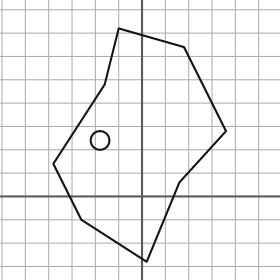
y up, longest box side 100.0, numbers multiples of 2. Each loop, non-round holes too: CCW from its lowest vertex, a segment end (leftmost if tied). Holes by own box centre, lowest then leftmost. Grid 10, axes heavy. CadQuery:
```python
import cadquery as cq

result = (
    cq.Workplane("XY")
    .moveTo(2.0, -28.0)
    .lineTo(16.0, 6.0)
    .lineTo(36.0, 28.0)
    .lineTo(18.0, 64.0)
    .lineTo(-10.0, 72.0)
    .lineTo(-16.0, 48.0)
    .lineTo(-38.0, 14.0)
    .lineTo(-26.0, -10.0)
    .close()
    .moveTo(-18.0, 24.0)
    .circle(4.0)
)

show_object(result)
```